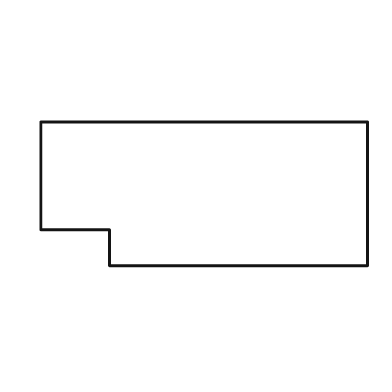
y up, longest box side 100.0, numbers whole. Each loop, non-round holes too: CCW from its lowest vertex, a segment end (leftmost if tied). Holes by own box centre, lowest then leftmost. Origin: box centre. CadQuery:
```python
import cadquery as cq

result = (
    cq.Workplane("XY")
    .moveTo(-29.0, -22.0)
    .lineTo(50.0, -22.0)
    .lineTo(50.0, 22.0)
    .lineTo(-50.0, 22.0)
    .lineTo(-50.0, -11.0)
    .lineTo(-29.0, -11.0)
    .close()
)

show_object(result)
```